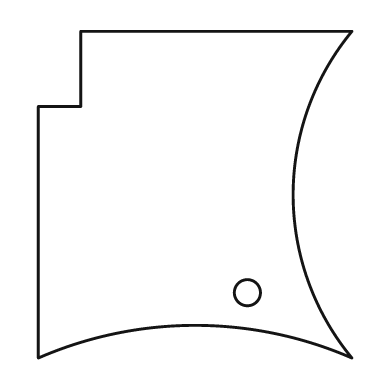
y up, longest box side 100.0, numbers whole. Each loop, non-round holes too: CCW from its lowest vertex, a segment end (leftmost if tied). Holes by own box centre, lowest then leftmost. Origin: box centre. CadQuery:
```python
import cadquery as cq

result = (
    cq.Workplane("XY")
    .moveTo(-48.0, -50.0)
    .threePointArc((0.0, -40.0), (48.0, -50.0))
    .threePointArc((30.0, 0.0), (48.0, 50.0))
    .lineTo(-35.0, 50.0)
    .lineTo(-35.0, 27.0)
    .lineTo(-48.0, 27.0)
    .close()
    .moveTo(16.0, -30.0)
    .circle(4.0)
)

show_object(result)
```